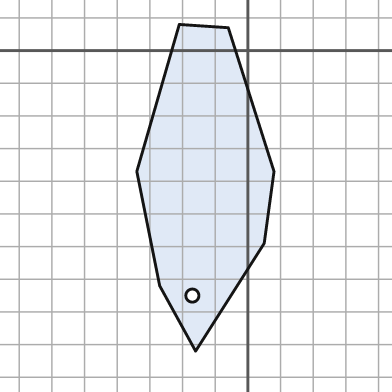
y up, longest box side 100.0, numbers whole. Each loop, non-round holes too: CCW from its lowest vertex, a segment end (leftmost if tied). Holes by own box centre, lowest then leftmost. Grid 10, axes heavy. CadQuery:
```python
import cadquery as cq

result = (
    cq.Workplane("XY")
    .moveTo(-16.0, -92.0)
    .lineTo(5.0, -59.0)
    .lineTo(8.0, -37.0)
    .lineTo(-6.0, 7.0)
    .lineTo(-21.0, 8.0)
    .lineTo(-34.0, -37.0)
    .lineTo(-27.0, -72.0)
    .close()
    .moveTo(-17.0, -75.0)
    .circle(2.0)
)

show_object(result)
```